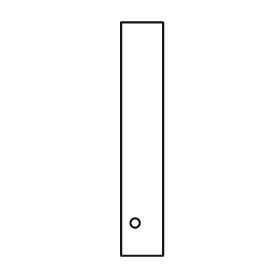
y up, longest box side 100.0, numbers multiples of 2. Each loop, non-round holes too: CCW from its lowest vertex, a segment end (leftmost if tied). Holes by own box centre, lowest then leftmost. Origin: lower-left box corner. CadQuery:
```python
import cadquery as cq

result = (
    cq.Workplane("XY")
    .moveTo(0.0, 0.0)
    .lineTo(18.0, 0.0)
    .lineTo(18.0, 100.0)
    .lineTo(0.0, 100.0)
    .close()
    .moveTo(6.0, 14.0)
    .circle(2.0)
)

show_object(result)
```